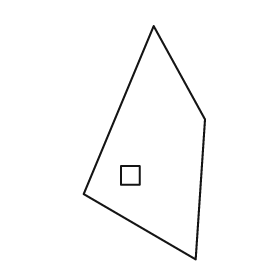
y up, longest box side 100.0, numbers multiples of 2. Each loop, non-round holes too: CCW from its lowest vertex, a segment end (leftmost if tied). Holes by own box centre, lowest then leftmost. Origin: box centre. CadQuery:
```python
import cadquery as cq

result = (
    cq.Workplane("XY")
    .moveTo(22.0, -50.0)
    .lineTo(26.0, 10.0)
    .lineTo(4.0, 50.0)
    .lineTo(-26.0, -22.0)
    .close()
    .moveTo(-10.0, -18.0)
    .lineTo(-2.0, -18.0)
    .lineTo(-2.0, -10.0)
    .lineTo(-10.0, -10.0)
    .close()
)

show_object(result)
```